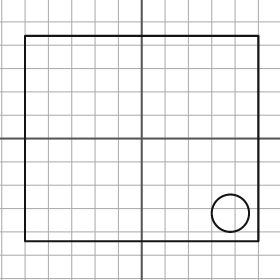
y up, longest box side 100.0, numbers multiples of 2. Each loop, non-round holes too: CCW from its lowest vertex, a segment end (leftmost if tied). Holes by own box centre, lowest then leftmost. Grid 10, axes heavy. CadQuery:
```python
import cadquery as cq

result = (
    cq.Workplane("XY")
    .moveTo(-50.0, -44.0)
    .lineTo(50.0, -44.0)
    .lineTo(50.0, 44.0)
    .lineTo(-50.0, 44.0)
    .close()
    .moveTo(38.0, -32.0)
    .circle(8.0)
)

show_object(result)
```